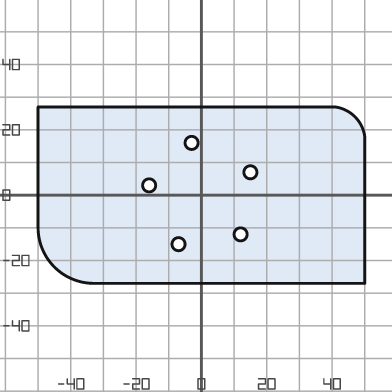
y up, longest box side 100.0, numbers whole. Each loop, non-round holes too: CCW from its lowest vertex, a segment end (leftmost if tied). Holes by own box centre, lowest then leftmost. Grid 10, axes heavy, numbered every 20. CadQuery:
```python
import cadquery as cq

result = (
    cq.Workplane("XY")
    .moveTo(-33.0, -27.0)
    .lineTo(50.0, -27.0)
    .lineTo(50.0, 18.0)
    .threePointArc((47.0, 24.0), (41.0, 27.0))
    .lineTo(-50.0, 27.0)
    .lineTo(-50.0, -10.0)
    .threePointArc((-45.0, -22.0), (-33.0, -27.0))
    .close()
    .moveTo(-7.0, -15.0)
    .circle(2.0)
    .moveTo(12.0, -12.0)
    .circle(2.0)
    .moveTo(-16.0, 3.0)
    .circle(2.0)
    .moveTo(15.0, 7.0)
    .circle(2.0)
    .moveTo(-3.0, 16.0)
    .circle(2.0)
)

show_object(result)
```